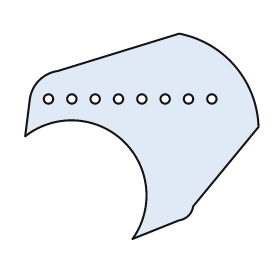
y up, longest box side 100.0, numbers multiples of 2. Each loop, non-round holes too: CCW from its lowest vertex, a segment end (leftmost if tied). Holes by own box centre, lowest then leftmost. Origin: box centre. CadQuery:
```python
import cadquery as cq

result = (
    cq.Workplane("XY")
    .moveTo(-4.0, -44.0)
    .lineTo(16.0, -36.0)
    .threePointArc((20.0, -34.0), (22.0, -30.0))
    .lineTo(50.0, 4.0)
    .threePointArc((40.0, 30.0), (16.0, 44.0))
    .lineTo(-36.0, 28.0)
    .threePointArc((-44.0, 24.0), (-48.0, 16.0))
    .lineTo(-50.0, 0.0)
    .threePointArc((-8.0, -2.0), (-4.0, -44.0))
    .close()
    .moveTo(-40.0, 16.0)
    .circle(2.0)
    .moveTo(-30.0, 16.0)
    .circle(2.0)
    .moveTo(-20.0, 16.0)
    .circle(2.0)
    .moveTo(-10.0, 16.0)
    .circle(2.0)
    .moveTo(0.0, 16.0)
    .circle(2.0)
    .moveTo(10.0, 16.0)
    .circle(2.0)
    .moveTo(20.0, 16.0)
    .circle(2.0)
    .moveTo(30.0, 16.0)
    .circle(2.0)
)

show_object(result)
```